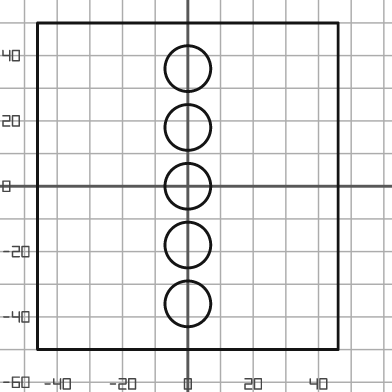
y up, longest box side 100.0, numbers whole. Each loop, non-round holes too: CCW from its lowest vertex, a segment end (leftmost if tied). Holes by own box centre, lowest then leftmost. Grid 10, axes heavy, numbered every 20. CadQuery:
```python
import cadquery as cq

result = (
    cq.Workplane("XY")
    .moveTo(-46.0, -50.0)
    .lineTo(46.0, -50.0)
    .lineTo(46.0, 50.0)
    .lineTo(-46.0, 50.0)
    .close()
    .moveTo(0.0, -36.0)
    .circle(7.0)
    .moveTo(0.0, -18.0)
    .circle(7.0)
    .moveTo(0.0, 0.0)
    .circle(7.0)
    .moveTo(0.0, 18.0)
    .circle(7.0)
    .moveTo(0.0, 36.0)
    .circle(7.0)
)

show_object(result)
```